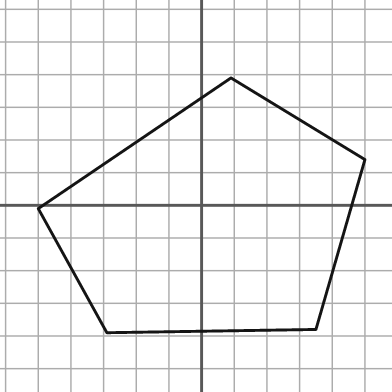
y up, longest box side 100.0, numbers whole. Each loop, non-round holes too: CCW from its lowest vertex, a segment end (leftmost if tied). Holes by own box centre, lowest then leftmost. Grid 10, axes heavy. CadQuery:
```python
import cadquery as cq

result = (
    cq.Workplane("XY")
    .moveTo(-29.0, -39.0)
    .lineTo(35.0, -38.0)
    .lineTo(50.0, 14.0)
    .lineTo(9.0, 39.0)
    .lineTo(-50.0, -1.0)
    .close()
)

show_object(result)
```